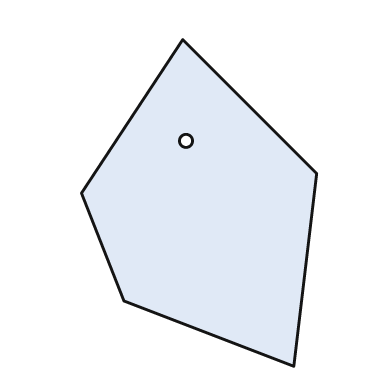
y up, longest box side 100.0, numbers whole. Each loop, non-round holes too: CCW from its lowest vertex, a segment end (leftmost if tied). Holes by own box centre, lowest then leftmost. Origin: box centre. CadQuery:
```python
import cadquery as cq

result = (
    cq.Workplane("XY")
    .moveTo(29.0, -50.0)
    .lineTo(36.0, 9.0)
    .lineTo(-5.0, 50.0)
    .lineTo(-36.0, 3.0)
    .lineTo(-23.0, -30.0)
    .close()
    .moveTo(-4.0, 19.0)
    .circle(2.0)
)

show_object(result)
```